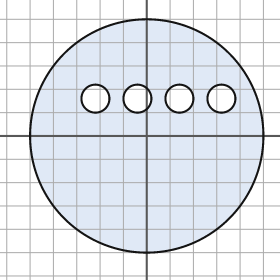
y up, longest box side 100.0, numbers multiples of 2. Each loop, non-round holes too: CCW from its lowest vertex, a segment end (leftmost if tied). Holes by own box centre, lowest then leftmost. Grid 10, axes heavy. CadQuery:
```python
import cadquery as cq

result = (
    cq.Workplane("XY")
    .moveTo(0.0, 0.0)
    .circle(50.0)
    .moveTo(-22.0, 16.0)
    .circle(6.0)
    .moveTo(-4.0, 16.0)
    .circle(6.0)
    .moveTo(14.0, 16.0)
    .circle(6.0)
    .moveTo(32.0, 16.0)
    .circle(6.0)
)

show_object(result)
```